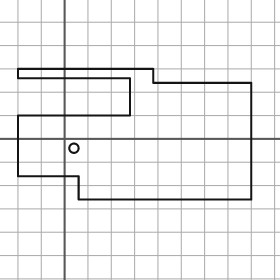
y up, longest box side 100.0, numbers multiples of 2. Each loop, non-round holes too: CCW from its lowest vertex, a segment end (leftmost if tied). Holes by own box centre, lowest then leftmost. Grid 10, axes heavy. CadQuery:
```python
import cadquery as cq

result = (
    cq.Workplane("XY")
    .moveTo(6.0, -26.0)
    .lineTo(80.0, -26.0)
    .lineTo(80.0, 24.0)
    .lineTo(38.0, 24.0)
    .lineTo(38.0, 30.0)
    .lineTo(-20.0, 30.0)
    .lineTo(-20.0, 26.0)
    .lineTo(28.0, 26.0)
    .lineTo(28.0, 10.0)
    .lineTo(-20.0, 10.0)
    .lineTo(-20.0, -16.0)
    .lineTo(6.0, -16.0)
    .close()
    .moveTo(4.0, -4.0)
    .circle(2.0)
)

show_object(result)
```